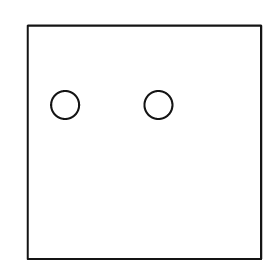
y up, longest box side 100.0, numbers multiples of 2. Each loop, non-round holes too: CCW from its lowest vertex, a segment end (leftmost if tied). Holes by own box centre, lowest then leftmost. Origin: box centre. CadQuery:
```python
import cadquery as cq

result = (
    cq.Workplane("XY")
    .moveTo(-50.0, -50.0)
    .lineTo(50.0, -50.0)
    .lineTo(50.0, 50.0)
    .lineTo(-50.0, 50.0)
    .close()
    .moveTo(-34.0, 16.0)
    .circle(6.0)
    .moveTo(6.0, 16.0)
    .circle(6.0)
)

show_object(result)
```